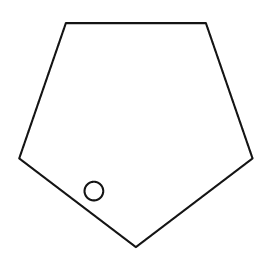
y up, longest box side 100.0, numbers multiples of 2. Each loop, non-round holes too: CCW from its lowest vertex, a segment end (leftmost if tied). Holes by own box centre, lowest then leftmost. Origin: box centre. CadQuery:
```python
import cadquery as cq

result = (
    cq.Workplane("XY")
    .moveTo(0.0, -48.0)
    .lineTo(50.0, -10.0)
    .lineTo(30.0, 48.0)
    .lineTo(-30.0, 48.0)
    .lineTo(-50.0, -10.0)
    .close()
    .moveTo(-18.0, -24.0)
    .circle(4.0)
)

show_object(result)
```